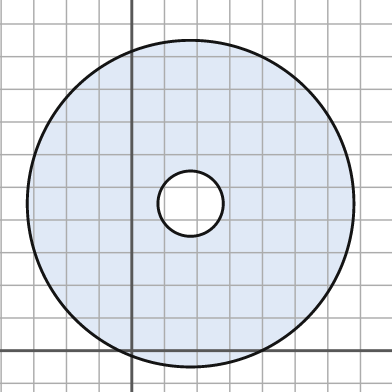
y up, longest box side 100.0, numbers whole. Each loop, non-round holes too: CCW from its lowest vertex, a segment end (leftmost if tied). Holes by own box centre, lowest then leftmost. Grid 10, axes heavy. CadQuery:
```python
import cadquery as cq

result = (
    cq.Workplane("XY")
    .moveTo(18.0, 45.0)
    .circle(50.0)
    .moveTo(18.0, 45.0)
    .circle(10.0)
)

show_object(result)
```